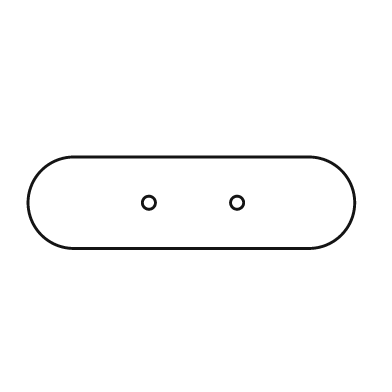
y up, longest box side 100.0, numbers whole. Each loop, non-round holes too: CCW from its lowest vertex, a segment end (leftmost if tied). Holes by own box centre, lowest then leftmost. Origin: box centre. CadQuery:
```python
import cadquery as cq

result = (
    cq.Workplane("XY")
    .moveTo(-36.0, -14.0)
    .lineTo(36.0, -14.0)
    .threePointArc((50.0, 0.0), (36.0, 14.0))
    .lineTo(-36.0, 14.0)
    .threePointArc((-50.0, 0.0), (-36.0, -14.0))
    .close()
    .moveTo(-13.0, 0.0)
    .circle(2.0)
    .moveTo(14.0, 0.0)
    .circle(2.0)
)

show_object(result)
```